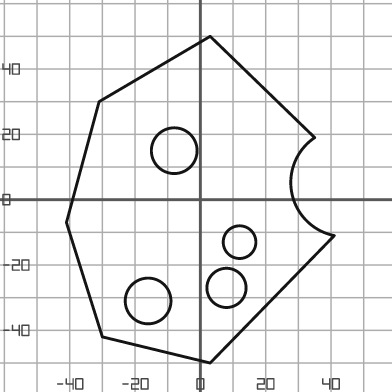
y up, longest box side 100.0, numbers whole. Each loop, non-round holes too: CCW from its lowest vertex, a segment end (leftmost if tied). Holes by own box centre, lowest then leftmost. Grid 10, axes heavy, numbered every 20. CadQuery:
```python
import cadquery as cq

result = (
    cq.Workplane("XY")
    .moveTo(3.0, -50.0)
    .lineTo(41.0, -11.0)
    .threePointArc((28.0, 2.0), (35.0, 19.0))
    .lineTo(3.0, 50.0)
    .lineTo(-31.0, 30.0)
    .lineTo(-41.0, -7.0)
    .lineTo(-30.0, -42.0)
    .close()
    .moveTo(-16.0, -31.0)
    .circle(7.0)
    .moveTo(8.0, -27.0)
    .circle(6.0)
    .moveTo(12.0, -13.0)
    .circle(5.0)
    .moveTo(-8.0, 15.0)
    .circle(7.0)
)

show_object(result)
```